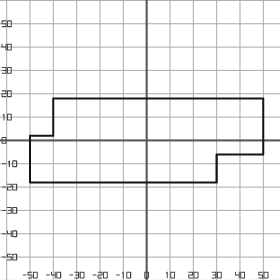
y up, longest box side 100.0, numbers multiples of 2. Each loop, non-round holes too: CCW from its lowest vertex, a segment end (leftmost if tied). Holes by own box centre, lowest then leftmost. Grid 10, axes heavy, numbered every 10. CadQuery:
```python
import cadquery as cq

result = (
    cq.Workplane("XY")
    .moveTo(-50.0, -18.0)
    .lineTo(30.0, -18.0)
    .lineTo(30.0, -6.0)
    .lineTo(50.0, -6.0)
    .lineTo(50.0, 18.0)
    .lineTo(-40.0, 18.0)
    .lineTo(-40.0, 2.0)
    .lineTo(-50.0, 2.0)
    .close()
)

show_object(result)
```